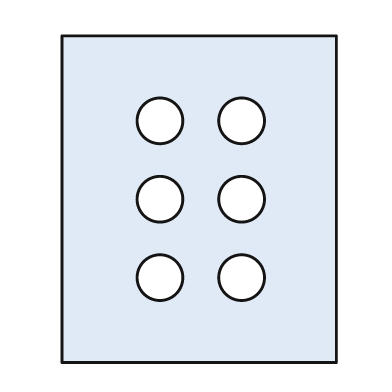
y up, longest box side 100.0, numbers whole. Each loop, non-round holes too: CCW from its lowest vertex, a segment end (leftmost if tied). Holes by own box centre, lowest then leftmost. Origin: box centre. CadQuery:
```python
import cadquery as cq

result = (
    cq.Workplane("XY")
    .moveTo(-42.0, -50.0)
    .lineTo(42.0, -50.0)
    .lineTo(42.0, 50.0)
    .lineTo(-42.0, 50.0)
    .close()
    .moveTo(-12.0, -24.0)
    .circle(7.0)
    .moveTo(13.0, -24.0)
    .circle(7.0)
    .moveTo(-12.0, 0.0)
    .circle(7.0)
    .moveTo(13.0, 0.0)
    .circle(7.0)
    .moveTo(-12.0, 24.0)
    .circle(7.0)
    .moveTo(13.0, 24.0)
    .circle(7.0)
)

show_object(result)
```